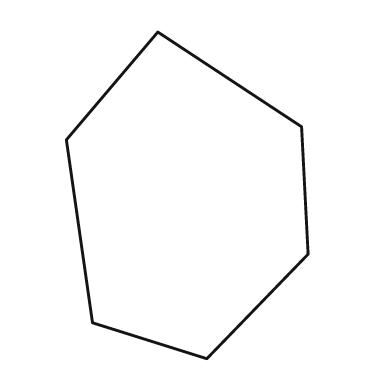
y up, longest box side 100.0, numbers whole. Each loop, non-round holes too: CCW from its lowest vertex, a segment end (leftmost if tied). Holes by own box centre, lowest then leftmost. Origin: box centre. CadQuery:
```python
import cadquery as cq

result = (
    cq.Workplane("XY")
    .moveTo(6.0, -50.0)
    .lineTo(37.0, -18.0)
    .lineTo(35.0, 21.0)
    .lineTo(-9.0, 50.0)
    .lineTo(-37.0, 17.0)
    .lineTo(-29.0, -39.0)
    .close()
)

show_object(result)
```